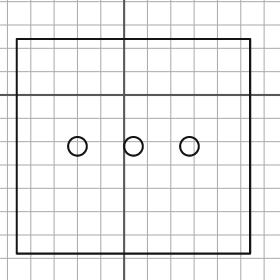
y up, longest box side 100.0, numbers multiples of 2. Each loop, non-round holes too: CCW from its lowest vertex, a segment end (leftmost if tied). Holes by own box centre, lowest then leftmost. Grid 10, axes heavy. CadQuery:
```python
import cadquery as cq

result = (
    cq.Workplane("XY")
    .moveTo(-46.0, -68.0)
    .lineTo(54.0, -68.0)
    .lineTo(54.0, 24.0)
    .lineTo(-46.0, 24.0)
    .close()
    .moveTo(-20.0, -22.0)
    .circle(4.0)
    .moveTo(4.0, -22.0)
    .circle(4.0)
    .moveTo(28.0, -22.0)
    .circle(4.0)
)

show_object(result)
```